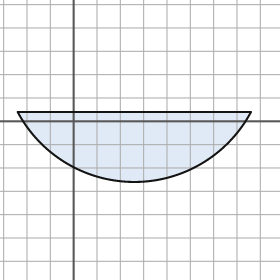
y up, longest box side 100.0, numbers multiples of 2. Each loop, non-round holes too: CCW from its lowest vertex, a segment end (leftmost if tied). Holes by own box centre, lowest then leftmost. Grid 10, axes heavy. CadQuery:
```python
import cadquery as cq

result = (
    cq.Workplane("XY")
    .moveTo(-24.0, 4.0)
    .threePointArc((26.0, -26.0), (76.0, 4.0))
    .close()
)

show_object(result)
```